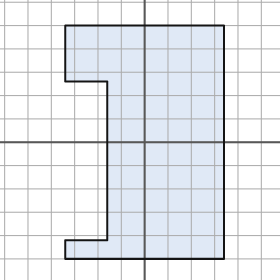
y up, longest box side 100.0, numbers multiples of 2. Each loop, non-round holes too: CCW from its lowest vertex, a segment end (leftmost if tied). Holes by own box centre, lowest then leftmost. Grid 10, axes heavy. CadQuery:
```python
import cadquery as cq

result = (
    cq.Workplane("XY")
    .moveTo(-34.0, -50.0)
    .lineTo(34.0, -50.0)
    .lineTo(34.0, 50.0)
    .lineTo(-34.0, 50.0)
    .lineTo(-34.0, 26.0)
    .lineTo(-16.0, 26.0)
    .lineTo(-16.0, -42.0)
    .lineTo(-34.0, -42.0)
    .close()
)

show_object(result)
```